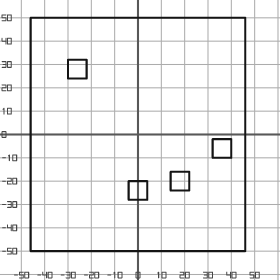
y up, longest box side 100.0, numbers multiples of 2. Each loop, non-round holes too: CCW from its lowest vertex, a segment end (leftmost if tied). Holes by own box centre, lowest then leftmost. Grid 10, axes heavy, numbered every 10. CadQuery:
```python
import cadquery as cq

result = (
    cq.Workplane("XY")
    .moveTo(-46.0, -50.0)
    .lineTo(46.0, -50.0)
    .lineTo(46.0, 50.0)
    .lineTo(-46.0, 50.0)
    .close()
    .moveTo(-4.0, -28.0)
    .lineTo(4.0, -28.0)
    .lineTo(4.0, -20.0)
    .lineTo(-4.0, -20.0)
    .close()
    .moveTo(14.0, -24.0)
    .lineTo(22.0, -24.0)
    .lineTo(22.0, -16.0)
    .lineTo(14.0, -16.0)
    .close()
    .moveTo(32.0, -10.0)
    .lineTo(40.0, -10.0)
    .lineTo(40.0, -2.0)
    .lineTo(32.0, -2.0)
    .close()
    .moveTo(-30.0, 24.0)
    .lineTo(-22.0, 24.0)
    .lineTo(-22.0, 32.0)
    .lineTo(-30.0, 32.0)
    .close()
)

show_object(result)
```